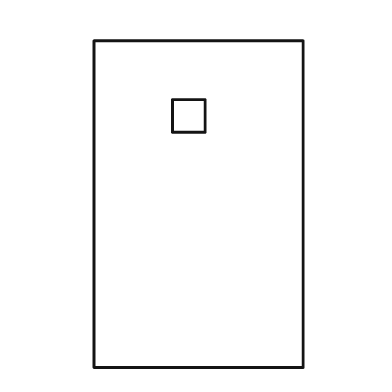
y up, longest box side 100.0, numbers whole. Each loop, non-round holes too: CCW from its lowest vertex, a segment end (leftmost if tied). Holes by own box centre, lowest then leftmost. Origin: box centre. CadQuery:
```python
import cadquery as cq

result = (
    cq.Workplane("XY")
    .moveTo(-32.0, -50.0)
    .lineTo(32.0, -50.0)
    .lineTo(32.0, 50.0)
    .lineTo(-32.0, 50.0)
    .close()
    .moveTo(-8.0, 22.0)
    .lineTo(2.0, 22.0)
    .lineTo(2.0, 32.0)
    .lineTo(-8.0, 32.0)
    .close()
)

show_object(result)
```